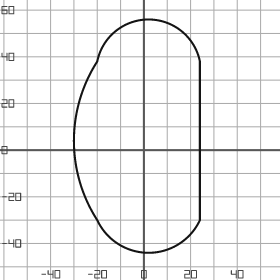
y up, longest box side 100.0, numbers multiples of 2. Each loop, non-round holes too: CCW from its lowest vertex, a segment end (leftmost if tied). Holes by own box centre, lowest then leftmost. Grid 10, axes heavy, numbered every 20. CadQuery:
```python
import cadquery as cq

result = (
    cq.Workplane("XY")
    .moveTo(-20.0, -30.0)
    .threePointArc((2.0, -44.0), (24.0, -30.0))
    .lineTo(24.0, 38.0)
    .threePointArc((2.0, 56.0), (-20.0, 38.0))
    .threePointArc((-30.0, 4.0), (-20.0, -30.0))
    .close()
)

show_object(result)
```